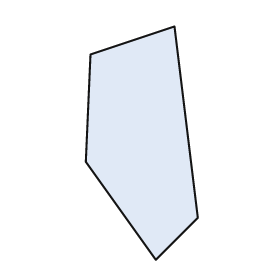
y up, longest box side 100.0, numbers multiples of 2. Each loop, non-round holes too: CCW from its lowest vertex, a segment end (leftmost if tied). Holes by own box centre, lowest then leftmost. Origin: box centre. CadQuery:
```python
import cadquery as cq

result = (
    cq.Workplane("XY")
    .moveTo(6.0, -50.0)
    .lineTo(24.0, -32.0)
    .lineTo(14.0, 50.0)
    .lineTo(-22.0, 38.0)
    .lineTo(-24.0, -8.0)
    .close()
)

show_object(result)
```